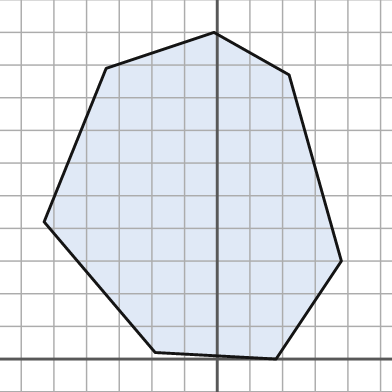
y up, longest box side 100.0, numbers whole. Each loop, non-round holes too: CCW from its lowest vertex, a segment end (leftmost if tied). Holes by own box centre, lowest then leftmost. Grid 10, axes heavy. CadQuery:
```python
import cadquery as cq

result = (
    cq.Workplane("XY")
    .moveTo(18.0, 0.0)
    .lineTo(38.0, 30.0)
    .lineTo(22.0, 87.0)
    .lineTo(-1.0, 100.0)
    .lineTo(-34.0, 89.0)
    .lineTo(-53.0, 42.0)
    .lineTo(-19.0, 2.0)
    .close()
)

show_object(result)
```